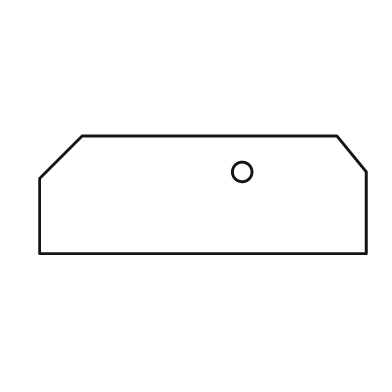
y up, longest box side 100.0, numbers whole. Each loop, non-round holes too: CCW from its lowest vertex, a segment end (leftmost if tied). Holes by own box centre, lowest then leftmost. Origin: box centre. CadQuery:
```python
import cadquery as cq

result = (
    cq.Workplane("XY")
    .moveTo(-50.0, -18.0)
    .lineTo(50.0, -18.0)
    .lineTo(50.0, 7.0)
    .lineTo(41.0, 18.0)
    .lineTo(-37.0, 18.0)
    .lineTo(-50.0, 5.0)
    .close()
    .moveTo(12.0, 7.0)
    .circle(3.0)
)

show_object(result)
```